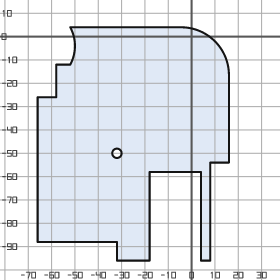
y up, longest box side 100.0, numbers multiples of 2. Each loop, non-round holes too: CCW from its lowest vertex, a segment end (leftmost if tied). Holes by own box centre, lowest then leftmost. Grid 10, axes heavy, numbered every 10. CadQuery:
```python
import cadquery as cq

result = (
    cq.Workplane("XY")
    .moveTo(-32.0, -96.0)
    .lineTo(-18.0, -96.0)
    .lineTo(-18.0, -58.0)
    .lineTo(4.0, -58.0)
    .lineTo(4.0, -96.0)
    .lineTo(8.0, -96.0)
    .lineTo(8.0, -54.0)
    .lineTo(16.0, -54.0)
    .lineTo(16.0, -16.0)
    .threePointArc((10.0, -2.0), (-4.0, 4.0))
    .lineTo(-52.0, 4.0)
    .threePointArc((-50.0, -4.0), (-52.0, -12.0))
    .lineTo(-58.0, -12.0)
    .lineTo(-58.0, -26.0)
    .lineTo(-66.0, -26.0)
    .lineTo(-66.0, -88.0)
    .lineTo(-32.0, -88.0)
    .close()
    .moveTo(-32.0, -50.0)
    .circle(2.0)
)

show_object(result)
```